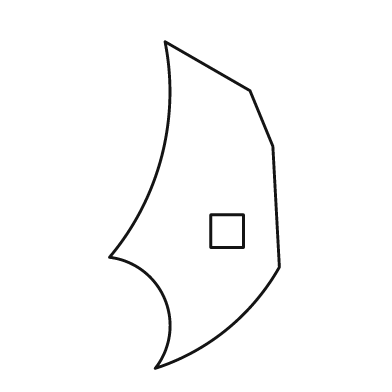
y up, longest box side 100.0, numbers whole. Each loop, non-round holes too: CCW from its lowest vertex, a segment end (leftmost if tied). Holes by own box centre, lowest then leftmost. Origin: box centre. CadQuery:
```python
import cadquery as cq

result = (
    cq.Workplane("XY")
    .moveTo(-12.0, -50.0)
    .threePointArc((10.0, -38.0), (26.0, -19.0))
    .lineTo(24.0, 18.0)
    .lineTo(17.0, 35.0)
    .lineTo(-9.0, 50.0)
    .threePointArc((-10.0, 15.0), (-26.0, -16.0))
    .threePointArc((-9.0, -29.0), (-12.0, -50.0))
    .close()
    .moveTo(5.0, -13.0)
    .lineTo(15.0, -13.0)
    .lineTo(15.0, -3.0)
    .lineTo(5.0, -3.0)
    .close()
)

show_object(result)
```